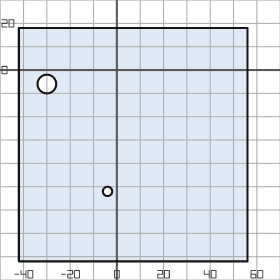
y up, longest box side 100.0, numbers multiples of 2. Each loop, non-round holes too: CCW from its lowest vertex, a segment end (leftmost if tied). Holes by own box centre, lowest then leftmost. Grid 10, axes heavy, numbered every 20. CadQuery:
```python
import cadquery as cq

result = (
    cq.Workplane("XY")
    .moveTo(-42.0, -82.0)
    .lineTo(56.0, -82.0)
    .lineTo(56.0, 18.0)
    .lineTo(-42.0, 18.0)
    .close()
    .moveTo(-4.0, -52.0)
    .circle(2.0)
    .moveTo(-30.0, -6.0)
    .circle(4.0)
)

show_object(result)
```